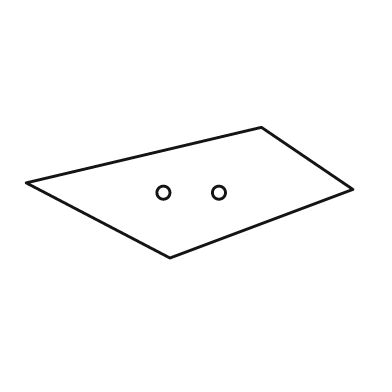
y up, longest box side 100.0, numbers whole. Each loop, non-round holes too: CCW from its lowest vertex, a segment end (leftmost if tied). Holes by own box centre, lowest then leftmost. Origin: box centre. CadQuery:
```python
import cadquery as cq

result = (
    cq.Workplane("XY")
    .moveTo(-6.0, -20.0)
    .lineTo(50.0, 1.0)
    .lineTo(22.0, 20.0)
    .lineTo(-50.0, 3.0)
    .close()
    .moveTo(-8.0, 0.0)
    .circle(2.0)
    .moveTo(9.0, 0.0)
    .circle(2.0)
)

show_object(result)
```